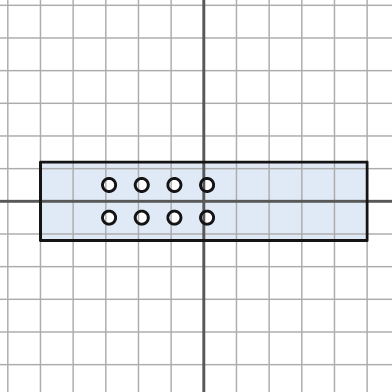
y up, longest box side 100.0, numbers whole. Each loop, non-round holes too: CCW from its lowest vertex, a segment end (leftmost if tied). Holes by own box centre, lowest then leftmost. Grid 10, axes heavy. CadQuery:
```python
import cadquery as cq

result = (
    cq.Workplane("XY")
    .moveTo(-50.0, -12.0)
    .lineTo(50.0, -12.0)
    .lineTo(50.0, 12.0)
    .lineTo(-50.0, 12.0)
    .close()
    .moveTo(-29.0, -5.0)
    .circle(2.0)
    .moveTo(-19.0, -5.0)
    .circle(2.0)
    .moveTo(-9.0, -5.0)
    .circle(2.0)
    .moveTo(1.0, -5.0)
    .circle(2.0)
    .moveTo(-29.0, 5.0)
    .circle(2.0)
    .moveTo(-19.0, 5.0)
    .circle(2.0)
    .moveTo(-9.0, 5.0)
    .circle(2.0)
    .moveTo(1.0, 5.0)
    .circle(2.0)
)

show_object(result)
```